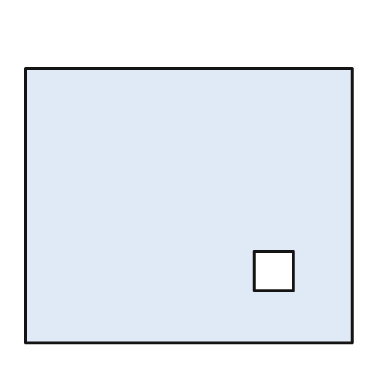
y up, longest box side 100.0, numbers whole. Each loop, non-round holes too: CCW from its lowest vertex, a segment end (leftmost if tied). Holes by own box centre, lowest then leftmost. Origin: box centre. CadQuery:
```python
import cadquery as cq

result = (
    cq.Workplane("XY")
    .moveTo(-50.0, -42.0)
    .lineTo(50.0, -42.0)
    .lineTo(50.0, 42.0)
    .lineTo(-50.0, 42.0)
    .close()
    .moveTo(20.0, -26.0)
    .lineTo(32.0, -26.0)
    .lineTo(32.0, -14.0)
    .lineTo(20.0, -14.0)
    .close()
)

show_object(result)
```